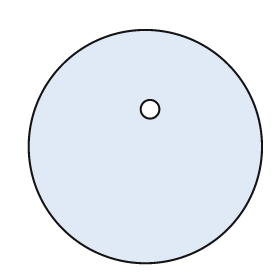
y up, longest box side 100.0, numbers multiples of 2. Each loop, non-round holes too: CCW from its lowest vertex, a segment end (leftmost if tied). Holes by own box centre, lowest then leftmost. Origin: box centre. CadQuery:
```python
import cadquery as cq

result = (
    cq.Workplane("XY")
    .moveTo(0.0, 0.0)
    .circle(50.0)
    .moveTo(2.0, 16.0)
    .circle(4.0)
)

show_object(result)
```